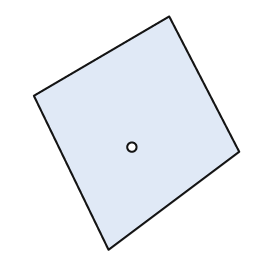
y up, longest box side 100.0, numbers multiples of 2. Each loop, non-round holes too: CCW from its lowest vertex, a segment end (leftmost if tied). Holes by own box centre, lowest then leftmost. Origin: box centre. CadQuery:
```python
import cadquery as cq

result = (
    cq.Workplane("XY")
    .moveTo(-12.0, -50.0)
    .lineTo(44.0, -8.0)
    .lineTo(14.0, 50.0)
    .lineTo(-44.0, 16.0)
    .close()
    .moveTo(-2.0, -6.0)
    .circle(2.0)
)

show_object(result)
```